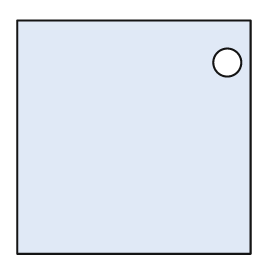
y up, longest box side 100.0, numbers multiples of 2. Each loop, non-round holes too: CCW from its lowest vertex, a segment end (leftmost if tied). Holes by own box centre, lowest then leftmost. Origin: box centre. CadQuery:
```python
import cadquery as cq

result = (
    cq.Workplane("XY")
    .moveTo(-50.0, -50.0)
    .lineTo(50.0, -50.0)
    .lineTo(50.0, 50.0)
    .lineTo(-50.0, 50.0)
    .close()
    .moveTo(40.0, 32.0)
    .circle(6.0)
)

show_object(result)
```